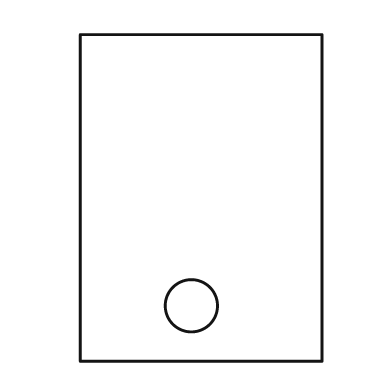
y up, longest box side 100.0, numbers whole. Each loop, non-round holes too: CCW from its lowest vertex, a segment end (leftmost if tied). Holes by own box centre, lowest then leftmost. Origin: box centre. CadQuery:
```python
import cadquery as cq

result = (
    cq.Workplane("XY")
    .moveTo(-37.0, -50.0)
    .lineTo(37.0, -50.0)
    .lineTo(37.0, 50.0)
    .lineTo(-37.0, 50.0)
    .close()
    .moveTo(-3.0, -33.0)
    .circle(8.0)
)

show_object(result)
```